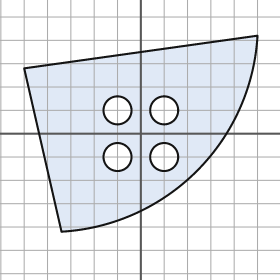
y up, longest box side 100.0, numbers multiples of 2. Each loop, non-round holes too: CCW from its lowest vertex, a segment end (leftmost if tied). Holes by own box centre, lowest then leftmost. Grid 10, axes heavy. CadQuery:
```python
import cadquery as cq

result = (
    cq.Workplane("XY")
    .moveTo(-34.0, -42.0)
    .threePointArc((24.0, -16.0), (50.0, 42.0))
    .lineTo(-50.0, 28.0)
    .close()
    .moveTo(-10.0, -10.0)
    .circle(6.0)
    .moveTo(10.0, -10.0)
    .circle(6.0)
    .moveTo(-10.0, 10.0)
    .circle(6.0)
    .moveTo(10.0, 10.0)
    .circle(6.0)
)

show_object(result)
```